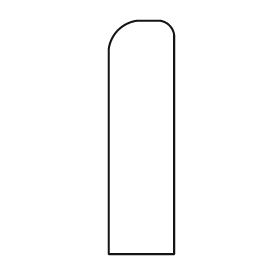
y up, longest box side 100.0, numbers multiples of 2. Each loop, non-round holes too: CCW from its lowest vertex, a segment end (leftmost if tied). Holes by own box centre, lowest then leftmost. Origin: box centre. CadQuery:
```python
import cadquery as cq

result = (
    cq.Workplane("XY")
    .moveTo(-14.0, -50.0)
    .lineTo(14.0, -50.0)
    .lineTo(14.0, 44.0)
    .threePointArc((12.0, 48.0), (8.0, 50.0))
    .lineTo(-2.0, 50.0)
    .threePointArc((-10.0, 46.0), (-14.0, 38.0))
    .close()
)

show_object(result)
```